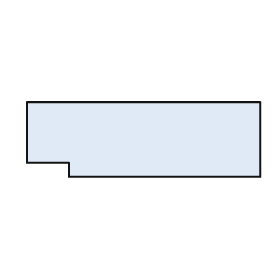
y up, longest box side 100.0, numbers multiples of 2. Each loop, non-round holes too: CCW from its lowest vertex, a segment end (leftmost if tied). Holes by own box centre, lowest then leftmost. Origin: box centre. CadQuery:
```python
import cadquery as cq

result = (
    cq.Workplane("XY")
    .moveTo(-32.0, -16.0)
    .lineTo(50.0, -16.0)
    .lineTo(50.0, 16.0)
    .lineTo(-50.0, 16.0)
    .lineTo(-50.0, -10.0)
    .lineTo(-32.0, -10.0)
    .close()
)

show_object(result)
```